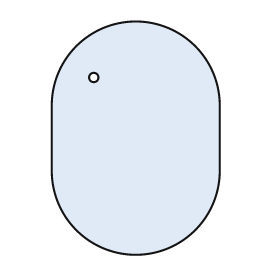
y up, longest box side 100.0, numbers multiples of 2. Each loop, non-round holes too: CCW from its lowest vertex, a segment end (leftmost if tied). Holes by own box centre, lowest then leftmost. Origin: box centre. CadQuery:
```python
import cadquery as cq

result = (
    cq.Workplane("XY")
    .moveTo(-36.0, -14.0)
    .threePointArc((0.0, -50.0), (36.0, -14.0))
    .lineTo(36.0, 14.0)
    .threePointArc((0.0, 50.0), (-36.0, 14.0))
    .close()
    .moveTo(-18.0, 26.0)
    .circle(2.0)
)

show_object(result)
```